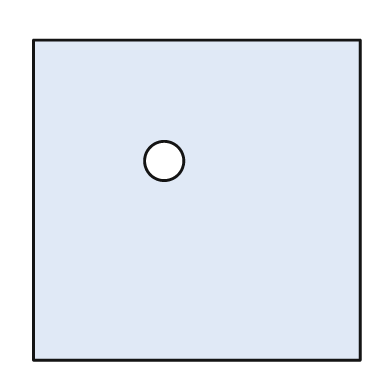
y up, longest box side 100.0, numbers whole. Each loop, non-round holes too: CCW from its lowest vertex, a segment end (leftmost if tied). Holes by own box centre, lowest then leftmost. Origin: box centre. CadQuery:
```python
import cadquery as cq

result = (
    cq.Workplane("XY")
    .moveTo(-50.0, -49.0)
    .lineTo(50.0, -49.0)
    .lineTo(50.0, 49.0)
    .lineTo(-50.0, 49.0)
    .close()
    .moveTo(-10.0, 12.0)
    .circle(6.0)
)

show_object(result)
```